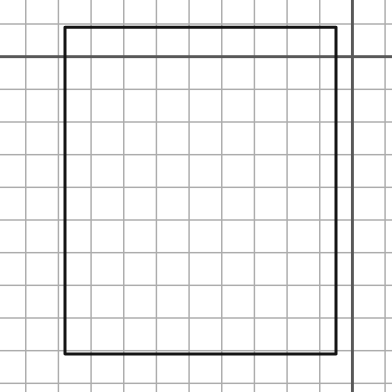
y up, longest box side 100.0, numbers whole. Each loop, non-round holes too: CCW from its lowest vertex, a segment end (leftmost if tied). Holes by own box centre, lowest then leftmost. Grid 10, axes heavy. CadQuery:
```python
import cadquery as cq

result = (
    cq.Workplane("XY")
    .moveTo(-88.0, -91.0)
    .lineTo(-5.0, -91.0)
    .lineTo(-5.0, 9.0)
    .lineTo(-88.0, 9.0)
    .close()
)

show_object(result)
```